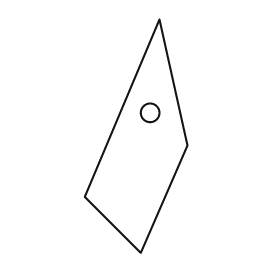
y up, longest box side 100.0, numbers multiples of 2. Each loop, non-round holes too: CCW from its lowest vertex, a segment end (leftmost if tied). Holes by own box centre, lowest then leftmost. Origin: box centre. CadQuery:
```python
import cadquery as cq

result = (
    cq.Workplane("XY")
    .moveTo(2.0, -50.0)
    .lineTo(22.0, -4.0)
    .lineTo(10.0, 50.0)
    .lineTo(-22.0, -26.0)
    .close()
    .moveTo(6.0, 10.0)
    .circle(4.0)
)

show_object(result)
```